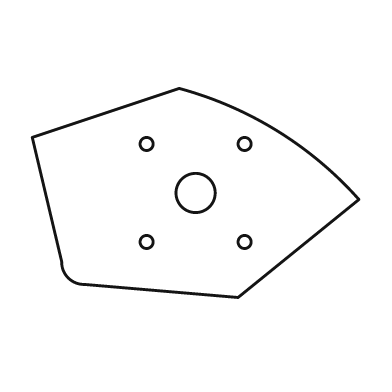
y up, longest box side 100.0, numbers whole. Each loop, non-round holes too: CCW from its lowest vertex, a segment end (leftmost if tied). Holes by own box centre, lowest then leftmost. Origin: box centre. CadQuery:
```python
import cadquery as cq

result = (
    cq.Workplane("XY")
    .moveTo(13.0, -32.0)
    .lineTo(50.0, -2.0)
    .threePointArc((25.0, 19.0), (-5.0, 32.0))
    .lineTo(-50.0, 17.0)
    .lineTo(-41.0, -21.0)
    .threePointArc((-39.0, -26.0), (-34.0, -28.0))
    .close()
    .moveTo(-15.0, -15.0)
    .circle(2.0)
    .moveTo(15.0, -15.0)
    .circle(2.0)
    .moveTo(0.0, 0.0)
    .circle(6.0)
    .moveTo(-15.0, 15.0)
    .circle(2.0)
    .moveTo(15.0, 15.0)
    .circle(2.0)
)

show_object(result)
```